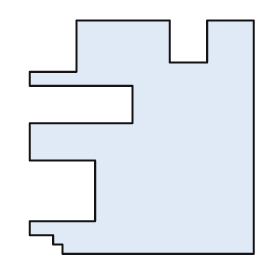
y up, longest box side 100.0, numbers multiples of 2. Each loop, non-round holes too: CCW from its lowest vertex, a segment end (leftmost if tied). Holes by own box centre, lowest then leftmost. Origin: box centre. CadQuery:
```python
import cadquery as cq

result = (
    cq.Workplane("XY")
    .moveTo(-34.0, -50.0)
    .lineTo(48.0, -50.0)
    .lineTo(48.0, 50.0)
    .lineTo(28.0, 50.0)
    .lineTo(28.0, 32.0)
    .lineTo(12.0, 32.0)
    .lineTo(12.0, 50.0)
    .lineTo(-28.0, 50.0)
    .lineTo(-28.0, 28.0)
    .lineTo(-48.0, 28.0)
    .lineTo(-48.0, 22.0)
    .lineTo(-4.0, 22.0)
    .lineTo(-4.0, 6.0)
    .lineTo(-48.0, 6.0)
    .lineTo(-48.0, -10.0)
    .lineTo(-20.0, -10.0)
    .lineTo(-20.0, -36.0)
    .lineTo(-48.0, -36.0)
    .lineTo(-48.0, -42.0)
    .lineTo(-38.0, -42.0)
    .lineTo(-38.0, -46.0)
    .lineTo(-34.0, -46.0)
    .close()
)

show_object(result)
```